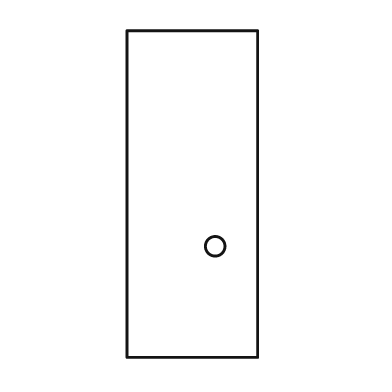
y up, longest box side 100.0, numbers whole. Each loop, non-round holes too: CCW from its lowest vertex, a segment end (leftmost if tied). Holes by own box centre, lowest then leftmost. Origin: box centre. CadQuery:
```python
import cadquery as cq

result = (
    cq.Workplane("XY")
    .moveTo(-20.0, -50.0)
    .lineTo(20.0, -50.0)
    .lineTo(20.0, 50.0)
    .lineTo(-20.0, 50.0)
    .close()
    .moveTo(7.0, -16.0)
    .circle(3.0)
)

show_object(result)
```